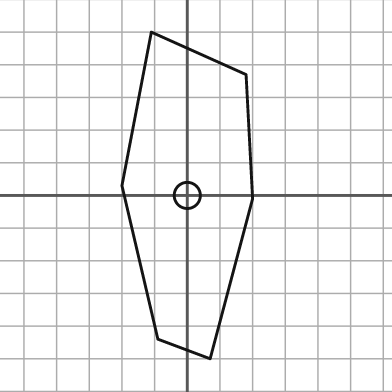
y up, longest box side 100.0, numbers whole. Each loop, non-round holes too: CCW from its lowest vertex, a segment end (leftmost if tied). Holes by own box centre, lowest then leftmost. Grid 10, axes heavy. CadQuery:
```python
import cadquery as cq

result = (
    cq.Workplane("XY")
    .moveTo(7.0, -50.0)
    .lineTo(20.0, -1.0)
    .lineTo(18.0, 37.0)
    .lineTo(-11.0, 50.0)
    .lineTo(-20.0, 3.0)
    .lineTo(-9.0, -44.0)
    .close()
    .moveTo(0.0, 0.0)
    .circle(4.0)
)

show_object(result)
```